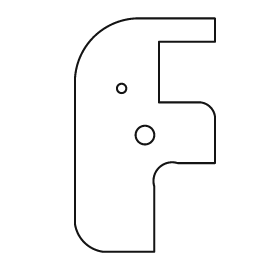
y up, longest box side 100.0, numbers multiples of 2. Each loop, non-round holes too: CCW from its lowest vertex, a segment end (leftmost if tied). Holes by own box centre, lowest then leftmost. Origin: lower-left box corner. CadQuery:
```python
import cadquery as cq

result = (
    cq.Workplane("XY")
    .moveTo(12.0, 0.0)
    .lineTo(34.0, 0.0)
    .lineTo(34.0, 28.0)
    .threePointArc((36.0, 36.0), (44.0, 38.0))
    .lineTo(60.0, 38.0)
    .lineTo(60.0, 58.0)
    .threePointArc((58.0, 62.0), (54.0, 64.0))
    .lineTo(36.0, 64.0)
    .lineTo(36.0, 90.0)
    .lineTo(60.0, 90.0)
    .lineTo(60.0, 100.0)
    .lineTo(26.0, 100.0)
    .threePointArc((8.0, 92.0), (0.0, 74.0))
    .lineTo(0.0, 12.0)
    .threePointArc((4.0, 4.0), (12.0, 0.0))
    .close()
    .moveTo(30.0, 50.0)
    .circle(4.0)
    .moveTo(20.0, 70.0)
    .circle(2.0)
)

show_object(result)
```